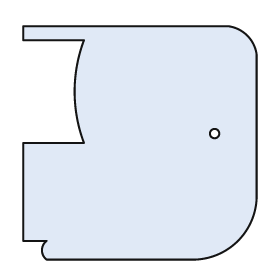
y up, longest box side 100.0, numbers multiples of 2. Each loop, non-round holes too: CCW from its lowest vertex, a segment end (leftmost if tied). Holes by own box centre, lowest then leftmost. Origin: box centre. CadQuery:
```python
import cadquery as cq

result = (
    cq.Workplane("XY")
    .moveTo(-40.0, -50.0)
    .lineTo(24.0, -50.0)
    .threePointArc((42.0, -42.0), (50.0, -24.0))
    .lineTo(50.0, 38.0)
    .threePointArc((46.0, 46.0), (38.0, 50.0))
    .lineTo(-50.0, 50.0)
    .lineTo(-50.0, 44.0)
    .lineTo(-24.0, 44.0)
    .threePointArc((-28.0, 22.0), (-24.0, 0.0))
    .lineTo(-50.0, 0.0)
    .lineTo(-50.0, -42.0)
    .lineTo(-40.0, -42.0)
    .threePointArc((-42.0, -46.0), (-40.0, -50.0))
    .close()
    .moveTo(32.0, 4.0)
    .circle(2.0)
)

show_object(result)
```